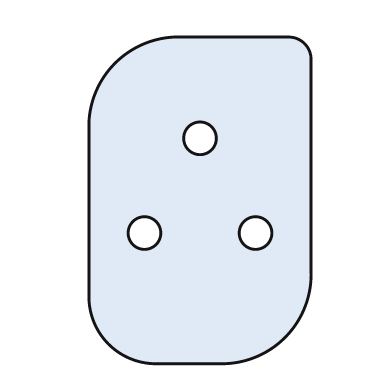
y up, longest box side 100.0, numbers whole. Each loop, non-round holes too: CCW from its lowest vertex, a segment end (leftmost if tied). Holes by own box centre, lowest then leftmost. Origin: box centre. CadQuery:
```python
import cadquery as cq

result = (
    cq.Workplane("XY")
    .moveTo(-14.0, -50.0)
    .lineTo(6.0, -50.0)
    .threePointArc((26.0, -42.0), (34.0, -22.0))
    .lineTo(34.0, 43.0)
    .threePointArc((32.0, 48.0), (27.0, 50.0))
    .lineTo(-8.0, 50.0)
    .threePointArc((-26.0, 42.0), (-34.0, 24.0))
    .lineTo(-34.0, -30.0)
    .threePointArc((-28.0, -44.0), (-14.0, -50.0))
    .close()
    .moveTo(-17.0, -10.0)
    .circle(5.0)
    .moveTo(17.0, -10.0)
    .circle(5.0)
    .moveTo(0.0, 19.0)
    .circle(5.0)
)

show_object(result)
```